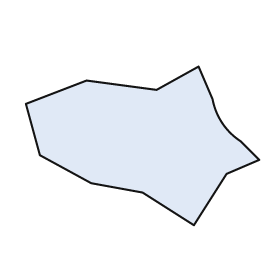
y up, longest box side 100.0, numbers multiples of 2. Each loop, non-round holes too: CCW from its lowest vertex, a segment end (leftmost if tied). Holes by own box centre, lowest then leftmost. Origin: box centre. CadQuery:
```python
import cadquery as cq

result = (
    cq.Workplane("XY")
    .moveTo(22.0, -34.0)
    .lineTo(36.0, -12.0)
    .lineTo(50.0, -6.0)
    .lineTo(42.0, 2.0)
    .threePointArc((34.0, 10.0), (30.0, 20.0))
    .lineTo(24.0, 34.0)
    .lineTo(6.0, 24.0)
    .lineTo(-24.0, 28.0)
    .lineTo(-50.0, 18.0)
    .lineTo(-44.0, -4.0)
    .lineTo(-22.0, -16.0)
    .lineTo(0.0, -20.0)
    .close()
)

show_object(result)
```